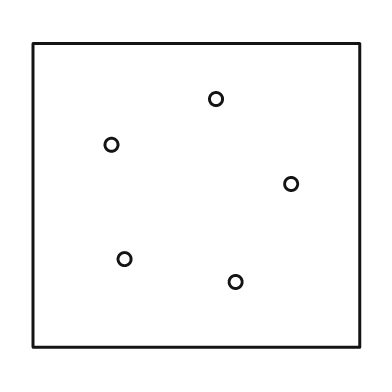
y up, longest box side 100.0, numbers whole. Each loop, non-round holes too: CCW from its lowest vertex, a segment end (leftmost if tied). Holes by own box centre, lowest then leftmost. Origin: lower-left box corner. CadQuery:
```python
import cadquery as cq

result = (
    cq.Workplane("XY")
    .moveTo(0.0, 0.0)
    .lineTo(100.0, 0.0)
    .lineTo(100.0, 93.0)
    .lineTo(0.0, 93.0)
    .close()
    .moveTo(62.0, 20.0)
    .circle(2.0)
    .moveTo(28.0, 27.0)
    .circle(2.0)
    .moveTo(79.0, 50.0)
    .circle(2.0)
    .moveTo(24.0, 62.0)
    .circle(2.0)
    .moveTo(56.0, 76.0)
    .circle(2.0)
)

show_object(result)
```